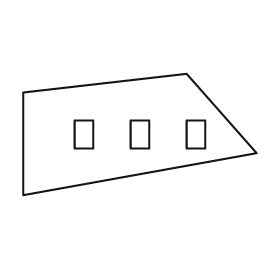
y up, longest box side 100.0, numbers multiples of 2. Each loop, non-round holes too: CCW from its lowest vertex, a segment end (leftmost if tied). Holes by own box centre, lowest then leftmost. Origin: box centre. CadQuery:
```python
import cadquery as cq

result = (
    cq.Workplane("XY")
    .moveTo(-50.0, -26.0)
    .lineTo(50.0, -8.0)
    .lineTo(20.0, 26.0)
    .lineTo(-50.0, 18.0)
    .close()
    .moveTo(-28.0, -6.0)
    .lineTo(-20.0, -6.0)
    .lineTo(-20.0, 6.0)
    .lineTo(-28.0, 6.0)
    .close()
    .moveTo(-4.0, -6.0)
    .lineTo(4.0, -6.0)
    .lineTo(4.0, 6.0)
    .lineTo(-4.0, 6.0)
    .close()
    .moveTo(20.0, -6.0)
    .lineTo(28.0, -6.0)
    .lineTo(28.0, 6.0)
    .lineTo(20.0, 6.0)
    .close()
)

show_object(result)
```